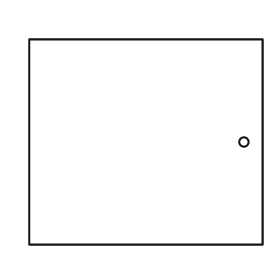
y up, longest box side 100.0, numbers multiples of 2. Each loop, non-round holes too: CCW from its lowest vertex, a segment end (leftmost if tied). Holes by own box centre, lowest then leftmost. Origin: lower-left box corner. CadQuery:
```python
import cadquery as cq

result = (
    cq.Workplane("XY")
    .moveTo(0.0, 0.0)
    .lineTo(100.0, 0.0)
    .lineTo(100.0, 88.0)
    .lineTo(0.0, 88.0)
    .close()
    .moveTo(92.0, 44.0)
    .circle(2.0)
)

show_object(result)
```